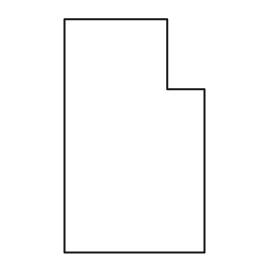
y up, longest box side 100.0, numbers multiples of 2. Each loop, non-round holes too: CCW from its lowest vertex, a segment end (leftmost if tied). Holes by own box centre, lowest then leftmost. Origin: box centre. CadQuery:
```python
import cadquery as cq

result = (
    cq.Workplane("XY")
    .moveTo(-30.0, -50.0)
    .lineTo(30.0, -50.0)
    .lineTo(30.0, 20.0)
    .lineTo(14.0, 20.0)
    .lineTo(14.0, 50.0)
    .lineTo(-30.0, 50.0)
    .close()
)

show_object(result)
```